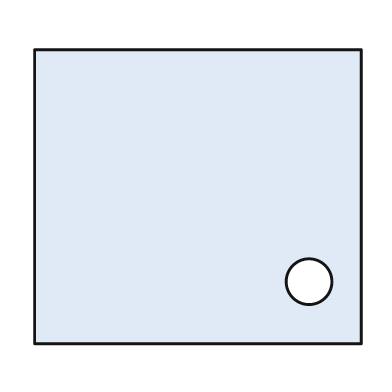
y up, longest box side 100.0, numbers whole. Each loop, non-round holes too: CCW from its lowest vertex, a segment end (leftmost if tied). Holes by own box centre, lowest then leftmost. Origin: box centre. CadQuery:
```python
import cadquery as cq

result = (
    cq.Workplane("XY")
    .moveTo(-50.0, -45.0)
    .lineTo(50.0, -45.0)
    .lineTo(50.0, 45.0)
    .lineTo(-50.0, 45.0)
    .close()
    .moveTo(34.0, -26.0)
    .circle(7.0)
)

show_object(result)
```